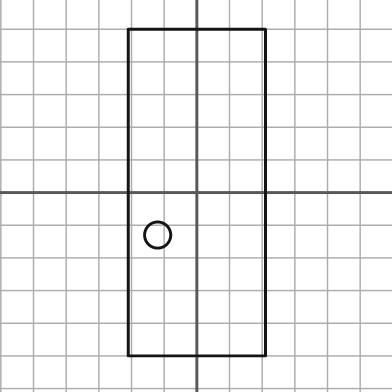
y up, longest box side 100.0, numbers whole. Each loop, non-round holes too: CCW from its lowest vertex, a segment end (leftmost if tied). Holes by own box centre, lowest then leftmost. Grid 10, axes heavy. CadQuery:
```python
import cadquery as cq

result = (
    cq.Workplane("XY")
    .moveTo(-21.0, -50.0)
    .lineTo(21.0, -50.0)
    .lineTo(21.0, 50.0)
    .lineTo(-21.0, 50.0)
    .close()
    .moveTo(-12.0, -13.0)
    .circle(4.0)
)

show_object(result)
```